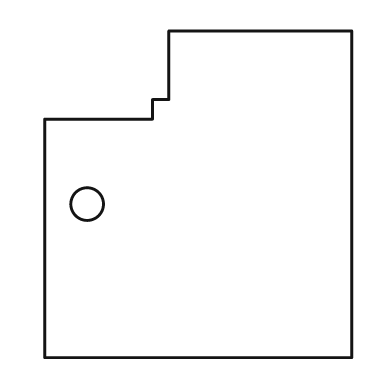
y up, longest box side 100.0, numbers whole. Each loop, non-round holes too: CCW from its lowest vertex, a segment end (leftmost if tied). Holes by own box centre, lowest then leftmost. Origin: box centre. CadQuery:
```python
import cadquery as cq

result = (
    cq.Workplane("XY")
    .moveTo(-47.0, -50.0)
    .lineTo(47.0, -50.0)
    .lineTo(47.0, 50.0)
    .lineTo(-9.0, 50.0)
    .lineTo(-9.0, 29.0)
    .lineTo(-14.0, 29.0)
    .lineTo(-14.0, 23.0)
    .lineTo(-47.0, 23.0)
    .close()
    .moveTo(-34.0, -3.0)
    .circle(5.0)
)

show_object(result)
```